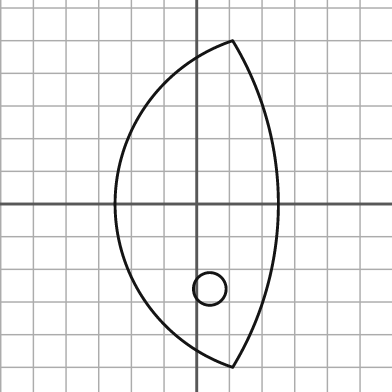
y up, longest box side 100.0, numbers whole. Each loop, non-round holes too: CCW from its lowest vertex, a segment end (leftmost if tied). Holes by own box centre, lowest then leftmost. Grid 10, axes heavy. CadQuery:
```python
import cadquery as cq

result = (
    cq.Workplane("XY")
    .moveTo(11.0, -50.0)
    .threePointArc((25.0, 0.0), (11.0, 50.0))
    .threePointArc((-25.0, 0.0), (11.0, -50.0))
    .close()
    .moveTo(4.0, -26.0)
    .circle(5.0)
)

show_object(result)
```